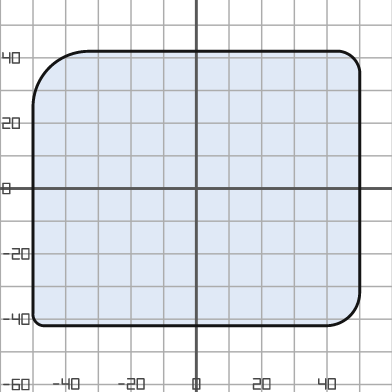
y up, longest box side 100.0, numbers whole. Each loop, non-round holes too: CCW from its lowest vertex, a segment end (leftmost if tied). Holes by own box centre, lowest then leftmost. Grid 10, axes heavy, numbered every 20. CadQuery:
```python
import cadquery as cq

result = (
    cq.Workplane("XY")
    .moveTo(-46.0, -42.0)
    .lineTo(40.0, -42.0)
    .threePointArc((47.0, -39.0), (50.0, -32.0))
    .lineTo(50.0, 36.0)
    .threePointArc((48.0, 40.0), (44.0, 42.0))
    .lineTo(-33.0, 42.0)
    .threePointArc((-45.0, 37.0), (-50.0, 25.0))
    .lineTo(-50.0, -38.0)
    .threePointArc((-49.0, -41.0), (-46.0, -42.0))
    .close()
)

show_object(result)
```